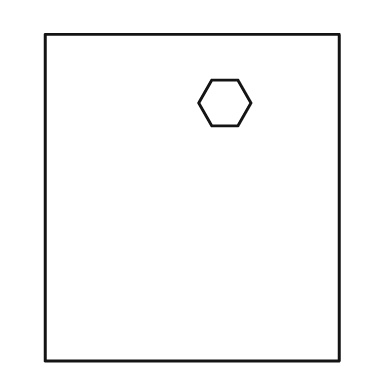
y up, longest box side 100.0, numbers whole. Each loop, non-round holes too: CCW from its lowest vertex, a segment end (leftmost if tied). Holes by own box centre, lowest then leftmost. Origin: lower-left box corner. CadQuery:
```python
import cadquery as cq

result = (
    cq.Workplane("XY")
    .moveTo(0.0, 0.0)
    .lineTo(90.0, 0.0)
    .lineTo(90.0, 100.0)
    .lineTo(0.0, 100.0)
    .close()
    .moveTo(51.0, 72.0)
    .lineTo(59.0, 72.0)
    .lineTo(63.0, 79.0)
    .lineTo(59.0, 86.0)
    .lineTo(51.0, 86.0)
    .lineTo(47.0, 79.0)
    .close()
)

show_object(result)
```